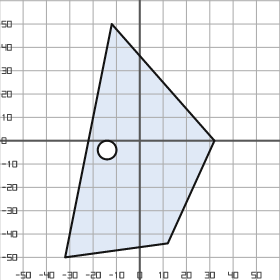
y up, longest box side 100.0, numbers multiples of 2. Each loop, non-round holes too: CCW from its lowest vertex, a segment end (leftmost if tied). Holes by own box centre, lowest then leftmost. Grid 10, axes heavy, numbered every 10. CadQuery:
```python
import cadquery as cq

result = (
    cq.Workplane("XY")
    .moveTo(-32.0, -50.0)
    .lineTo(12.0, -44.0)
    .lineTo(32.0, 0.0)
    .lineTo(-12.0, 50.0)
    .close()
    .moveTo(-14.0, -4.0)
    .circle(4.0)
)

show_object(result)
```